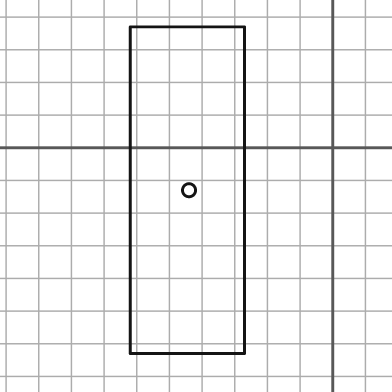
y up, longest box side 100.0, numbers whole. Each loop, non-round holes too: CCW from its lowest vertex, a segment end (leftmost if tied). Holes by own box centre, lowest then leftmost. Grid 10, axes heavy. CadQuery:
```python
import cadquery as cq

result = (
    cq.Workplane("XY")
    .moveTo(-62.0, -63.0)
    .lineTo(-27.0, -63.0)
    .lineTo(-27.0, 37.0)
    .lineTo(-62.0, 37.0)
    .close()
    .moveTo(-44.0, -13.0)
    .circle(2.0)
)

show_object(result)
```